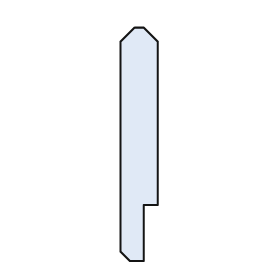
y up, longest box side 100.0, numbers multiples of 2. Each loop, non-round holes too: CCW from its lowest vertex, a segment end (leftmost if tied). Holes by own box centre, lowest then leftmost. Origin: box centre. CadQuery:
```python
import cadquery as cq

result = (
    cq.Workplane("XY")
    .moveTo(-4.0, -50.0)
    .lineTo(2.0, -50.0)
    .lineTo(2.0, -26.0)
    .lineTo(8.0, -26.0)
    .lineTo(8.0, 44.0)
    .lineTo(2.0, 50.0)
    .lineTo(-2.0, 50.0)
    .lineTo(-8.0, 44.0)
    .lineTo(-8.0, -46.0)
    .close()
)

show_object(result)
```